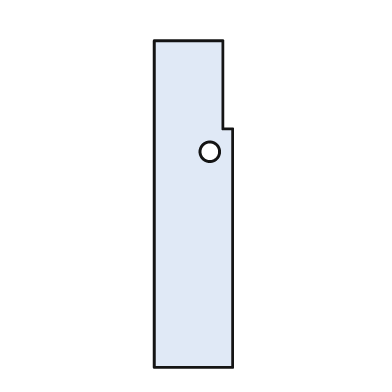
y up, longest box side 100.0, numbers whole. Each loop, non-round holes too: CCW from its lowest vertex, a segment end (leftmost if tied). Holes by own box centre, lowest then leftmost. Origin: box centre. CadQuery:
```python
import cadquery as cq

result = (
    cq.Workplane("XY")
    .moveTo(-12.0, -50.0)
    .lineTo(12.0, -50.0)
    .lineTo(12.0, 23.0)
    .lineTo(9.0, 23.0)
    .lineTo(9.0, 50.0)
    .lineTo(-12.0, 50.0)
    .close()
    .moveTo(5.0, 16.0)
    .circle(3.0)
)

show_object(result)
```